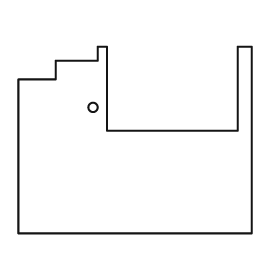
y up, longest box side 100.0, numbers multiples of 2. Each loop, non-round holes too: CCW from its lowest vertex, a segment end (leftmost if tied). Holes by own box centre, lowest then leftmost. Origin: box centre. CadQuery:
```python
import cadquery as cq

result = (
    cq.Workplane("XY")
    .moveTo(-50.0, -40.0)
    .lineTo(50.0, -40.0)
    .lineTo(50.0, 40.0)
    .lineTo(44.0, 40.0)
    .lineTo(44.0, 4.0)
    .lineTo(-12.0, 4.0)
    .lineTo(-12.0, 40.0)
    .lineTo(-16.0, 40.0)
    .lineTo(-16.0, 34.0)
    .lineTo(-34.0, 34.0)
    .lineTo(-34.0, 26.0)
    .lineTo(-50.0, 26.0)
    .close()
    .moveTo(-18.0, 14.0)
    .circle(2.0)
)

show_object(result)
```